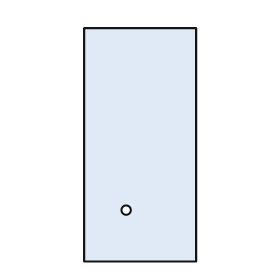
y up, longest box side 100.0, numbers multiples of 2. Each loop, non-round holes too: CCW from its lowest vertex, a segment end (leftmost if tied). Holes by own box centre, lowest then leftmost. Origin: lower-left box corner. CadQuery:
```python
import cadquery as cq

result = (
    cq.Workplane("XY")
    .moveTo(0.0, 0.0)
    .lineTo(48.0, 0.0)
    .lineTo(48.0, 100.0)
    .lineTo(0.0, 100.0)
    .close()
    .moveTo(18.0, 22.0)
    .circle(2.0)
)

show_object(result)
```